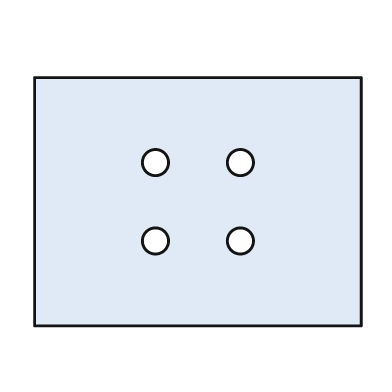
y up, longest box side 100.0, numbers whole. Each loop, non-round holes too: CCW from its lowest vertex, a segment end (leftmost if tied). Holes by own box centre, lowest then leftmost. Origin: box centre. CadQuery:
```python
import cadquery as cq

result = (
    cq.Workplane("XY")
    .moveTo(-50.0, -38.0)
    .lineTo(50.0, -38.0)
    .lineTo(50.0, 38.0)
    .lineTo(-50.0, 38.0)
    .close()
    .moveTo(-13.0, -12.0)
    .circle(4.0)
    .moveTo(13.0, -12.0)
    .circle(4.0)
    .moveTo(-13.0, 12.0)
    .circle(4.0)
    .moveTo(13.0, 12.0)
    .circle(4.0)
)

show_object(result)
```